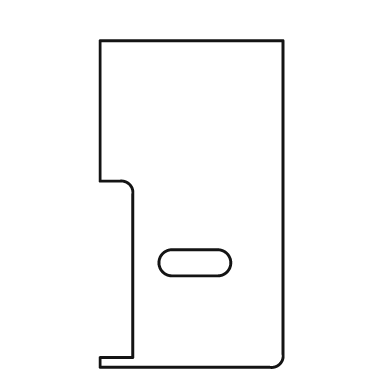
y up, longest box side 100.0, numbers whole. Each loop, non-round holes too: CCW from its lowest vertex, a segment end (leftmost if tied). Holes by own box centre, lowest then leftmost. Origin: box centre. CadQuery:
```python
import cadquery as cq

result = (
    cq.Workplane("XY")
    .moveTo(-28.0, -50.0)
    .lineTo(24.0, -50.0)
    .threePointArc((27.0, -49.0), (28.0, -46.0))
    .lineTo(28.0, 50.0)
    .lineTo(-28.0, 50.0)
    .lineTo(-28.0, 7.0)
    .lineTo(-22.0, 7.0)
    .threePointArc((-19.0, 6.0), (-18.0, 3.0))
    .lineTo(-18.0, -47.0)
    .lineTo(-28.0, -47.0)
    .close()
    .moveTo(-6.0, -22.0)
    .lineTo(8.0, -22.0)
    .threePointArc((12.0, -18.0), (8.0, -14.0))
    .lineTo(-6.0, -14.0)
    .threePointArc((-10.0, -18.0), (-6.0, -22.0))
    .close()
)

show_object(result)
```